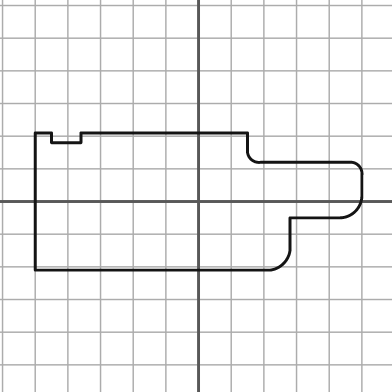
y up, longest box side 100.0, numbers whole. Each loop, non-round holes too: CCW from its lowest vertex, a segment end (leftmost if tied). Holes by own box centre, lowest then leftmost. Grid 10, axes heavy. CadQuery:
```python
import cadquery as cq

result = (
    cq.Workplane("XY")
    .moveTo(-50.0, -21.0)
    .lineTo(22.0, -21.0)
    .threePointArc((26.0, -19.0), (28.0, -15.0))
    .lineTo(28.0, -5.0)
    .lineTo(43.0, -5.0)
    .threePointArc((48.0, -3.0), (50.0, 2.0))
    .lineTo(50.0, 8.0)
    .threePointArc((49.0, 11.0), (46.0, 12.0))
    .lineTo(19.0, 12.0)
    .threePointArc((16.0, 13.0), (15.0, 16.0))
    .lineTo(15.0, 21.0)
    .lineTo(-36.0, 21.0)
    .lineTo(-36.0, 18.0)
    .lineTo(-45.0, 18.0)
    .lineTo(-45.0, 21.0)
    .lineTo(-50.0, 21.0)
    .close()
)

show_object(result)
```